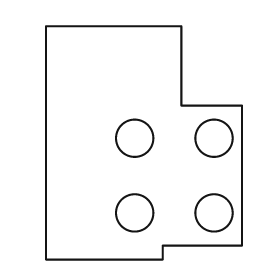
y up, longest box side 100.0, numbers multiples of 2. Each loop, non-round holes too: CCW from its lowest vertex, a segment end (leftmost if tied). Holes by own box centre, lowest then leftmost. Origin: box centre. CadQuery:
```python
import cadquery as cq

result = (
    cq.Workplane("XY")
    .moveTo(-42.0, -50.0)
    .lineTo(8.0, -50.0)
    .lineTo(8.0, -44.0)
    .lineTo(42.0, -44.0)
    .lineTo(42.0, 16.0)
    .lineTo(16.0, 16.0)
    .lineTo(16.0, 50.0)
    .lineTo(-42.0, 50.0)
    .close()
    .moveTo(-4.0, -30.0)
    .circle(8.0)
    .moveTo(30.0, -30.0)
    .circle(8.0)
    .moveTo(-4.0, 2.0)
    .circle(8.0)
    .moveTo(30.0, 2.0)
    .circle(8.0)
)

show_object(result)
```